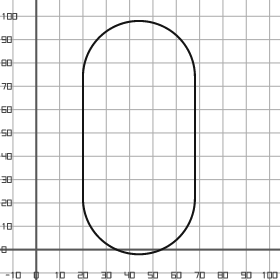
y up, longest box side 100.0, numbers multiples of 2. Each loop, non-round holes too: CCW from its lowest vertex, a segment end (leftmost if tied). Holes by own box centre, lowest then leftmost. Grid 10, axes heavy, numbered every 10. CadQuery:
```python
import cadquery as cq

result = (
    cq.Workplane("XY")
    .moveTo(20.0, 22.0)
    .threePointArc((44.0, -2.0), (68.0, 22.0))
    .lineTo(68.0, 74.0)
    .threePointArc((44.0, 98.0), (20.0, 74.0))
    .close()
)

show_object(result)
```